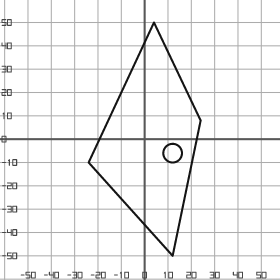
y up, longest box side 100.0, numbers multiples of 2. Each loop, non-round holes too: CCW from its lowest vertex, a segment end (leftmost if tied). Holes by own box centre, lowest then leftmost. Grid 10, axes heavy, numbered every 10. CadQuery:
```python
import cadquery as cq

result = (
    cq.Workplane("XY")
    .moveTo(12.0, -50.0)
    .lineTo(24.0, 8.0)
    .lineTo(4.0, 50.0)
    .lineTo(-24.0, -10.0)
    .close()
    .moveTo(12.0, -6.0)
    .circle(4.0)
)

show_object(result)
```